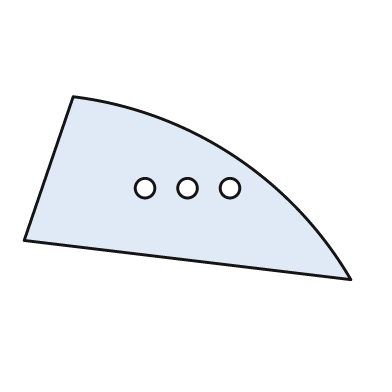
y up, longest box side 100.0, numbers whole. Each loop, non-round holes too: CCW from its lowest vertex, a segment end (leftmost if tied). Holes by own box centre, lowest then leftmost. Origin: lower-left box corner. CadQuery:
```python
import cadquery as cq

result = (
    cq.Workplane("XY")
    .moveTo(100.0, 0.0)
    .threePointArc((64.0, 38.0), (15.0, 56.0))
    .lineTo(0.0, 12.0)
    .close()
    .moveTo(37.0, 28.0)
    .circle(3.0)
    .moveTo(50.0, 28.0)
    .circle(3.0)
    .moveTo(63.0, 28.0)
    .circle(3.0)
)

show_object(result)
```